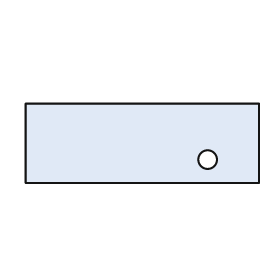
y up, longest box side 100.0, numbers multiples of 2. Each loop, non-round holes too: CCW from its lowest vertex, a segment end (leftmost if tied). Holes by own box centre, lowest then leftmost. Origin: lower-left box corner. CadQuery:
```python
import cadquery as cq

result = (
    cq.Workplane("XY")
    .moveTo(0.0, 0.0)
    .lineTo(100.0, 0.0)
    .lineTo(100.0, 34.0)
    .lineTo(0.0, 34.0)
    .close()
    .moveTo(78.0, 10.0)
    .circle(4.0)
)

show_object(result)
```